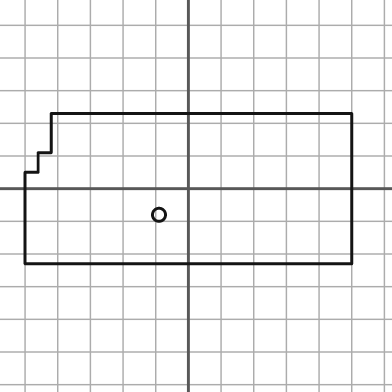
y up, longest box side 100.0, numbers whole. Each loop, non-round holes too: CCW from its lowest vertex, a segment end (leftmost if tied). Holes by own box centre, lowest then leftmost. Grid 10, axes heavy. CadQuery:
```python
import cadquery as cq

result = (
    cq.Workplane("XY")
    .moveTo(-50.0, -23.0)
    .lineTo(50.0, -23.0)
    .lineTo(50.0, 23.0)
    .lineTo(-42.0, 23.0)
    .lineTo(-42.0, 11.0)
    .lineTo(-46.0, 11.0)
    .lineTo(-46.0, 5.0)
    .lineTo(-50.0, 5.0)
    .close()
    .moveTo(-9.0, -8.0)
    .circle(2.0)
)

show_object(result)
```